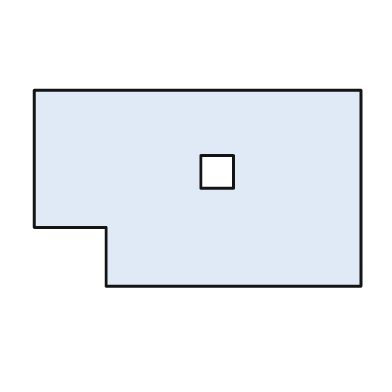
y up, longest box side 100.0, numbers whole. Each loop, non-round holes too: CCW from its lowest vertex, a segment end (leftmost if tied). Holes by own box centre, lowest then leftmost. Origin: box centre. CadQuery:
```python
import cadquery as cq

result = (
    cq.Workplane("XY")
    .moveTo(-28.0, -30.0)
    .lineTo(50.0, -30.0)
    .lineTo(50.0, 30.0)
    .lineTo(-50.0, 30.0)
    .lineTo(-50.0, -12.0)
    .lineTo(-28.0, -12.0)
    .close()
    .moveTo(1.0, 0.0)
    .lineTo(11.0, 0.0)
    .lineTo(11.0, 10.0)
    .lineTo(1.0, 10.0)
    .close()
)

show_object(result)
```